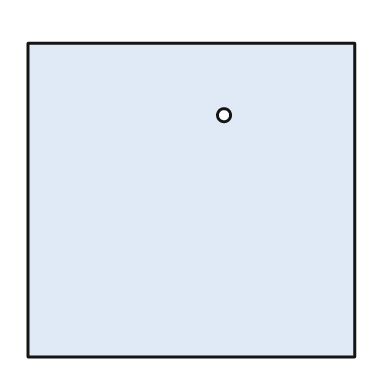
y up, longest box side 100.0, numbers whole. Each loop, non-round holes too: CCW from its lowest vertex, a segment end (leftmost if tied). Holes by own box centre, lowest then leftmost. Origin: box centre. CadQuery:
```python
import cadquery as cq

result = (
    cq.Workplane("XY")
    .moveTo(-50.0, -48.0)
    .lineTo(50.0, -48.0)
    .lineTo(50.0, 48.0)
    .lineTo(-50.0, 48.0)
    .close()
    .moveTo(10.0, 26.0)
    .circle(2.0)
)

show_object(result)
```